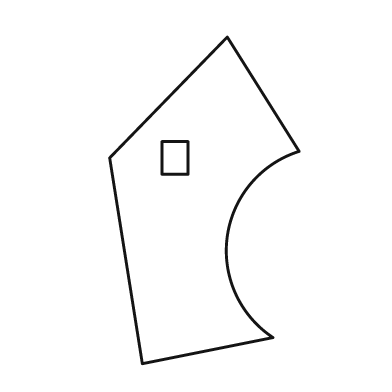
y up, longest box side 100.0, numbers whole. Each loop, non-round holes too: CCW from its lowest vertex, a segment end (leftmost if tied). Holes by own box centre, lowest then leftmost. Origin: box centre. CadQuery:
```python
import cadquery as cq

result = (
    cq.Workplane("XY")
    .moveTo(-19.0, -50.0)
    .lineTo(21.0, -42.0)
    .threePointArc((7.0, -11.0), (29.0, 15.0))
    .lineTo(7.0, 50.0)
    .lineTo(-29.0, 13.0)
    .close()
    .moveTo(-13.0, 8.0)
    .lineTo(-5.0, 8.0)
    .lineTo(-5.0, 18.0)
    .lineTo(-13.0, 18.0)
    .close()
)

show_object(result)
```